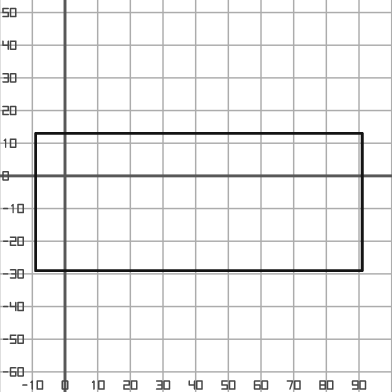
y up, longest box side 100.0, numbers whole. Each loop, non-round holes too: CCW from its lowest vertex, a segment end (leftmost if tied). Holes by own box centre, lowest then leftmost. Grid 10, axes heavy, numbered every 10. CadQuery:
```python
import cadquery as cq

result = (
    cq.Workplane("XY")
    .moveTo(-9.0, -29.0)
    .lineTo(91.0, -29.0)
    .lineTo(91.0, 13.0)
    .lineTo(-9.0, 13.0)
    .close()
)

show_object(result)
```